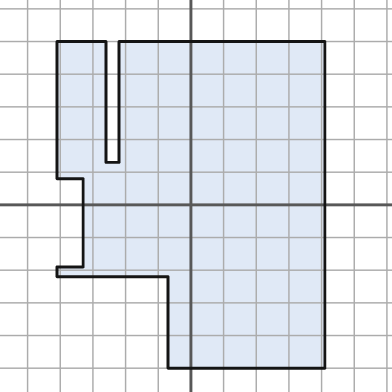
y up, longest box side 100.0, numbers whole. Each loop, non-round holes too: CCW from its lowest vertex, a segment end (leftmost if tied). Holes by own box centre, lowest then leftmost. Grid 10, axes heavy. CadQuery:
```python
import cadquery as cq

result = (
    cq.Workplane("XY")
    .moveTo(-7.0, -50.0)
    .lineTo(41.0, -50.0)
    .lineTo(41.0, 50.0)
    .lineTo(-22.0, 50.0)
    .lineTo(-22.0, 13.0)
    .lineTo(-26.0, 13.0)
    .lineTo(-26.0, 50.0)
    .lineTo(-41.0, 50.0)
    .lineTo(-41.0, 8.0)
    .lineTo(-33.0, 8.0)
    .lineTo(-33.0, -19.0)
    .lineTo(-41.0, -19.0)
    .lineTo(-41.0, -22.0)
    .lineTo(-7.0, -22.0)
    .close()
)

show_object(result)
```